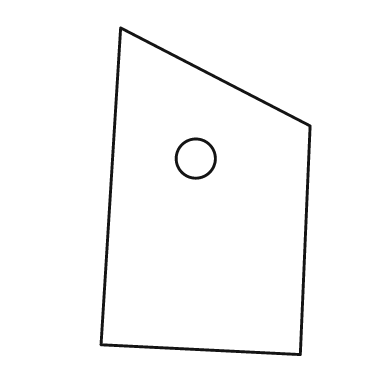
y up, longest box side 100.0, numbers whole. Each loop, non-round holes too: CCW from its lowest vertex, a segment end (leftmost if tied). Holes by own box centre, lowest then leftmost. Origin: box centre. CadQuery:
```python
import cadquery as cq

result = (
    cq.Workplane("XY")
    .moveTo(29.0, -50.0)
    .lineTo(32.0, 20.0)
    .lineTo(-26.0, 50.0)
    .lineTo(-32.0, -47.0)
    .close()
    .moveTo(-3.0, 10.0)
    .circle(6.0)
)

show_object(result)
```